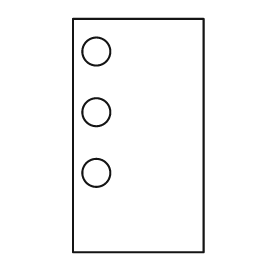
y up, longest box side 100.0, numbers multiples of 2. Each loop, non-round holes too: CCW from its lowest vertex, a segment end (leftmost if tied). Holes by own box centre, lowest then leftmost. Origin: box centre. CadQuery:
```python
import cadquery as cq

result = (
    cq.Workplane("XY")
    .moveTo(-28.0, -50.0)
    .lineTo(28.0, -50.0)
    .lineTo(28.0, 50.0)
    .lineTo(-28.0, 50.0)
    .close()
    .moveTo(-18.0, -16.0)
    .circle(6.0)
    .moveTo(-18.0, 10.0)
    .circle(6.0)
    .moveTo(-18.0, 36.0)
    .circle(6.0)
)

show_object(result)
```